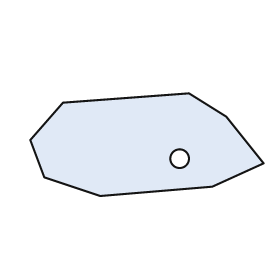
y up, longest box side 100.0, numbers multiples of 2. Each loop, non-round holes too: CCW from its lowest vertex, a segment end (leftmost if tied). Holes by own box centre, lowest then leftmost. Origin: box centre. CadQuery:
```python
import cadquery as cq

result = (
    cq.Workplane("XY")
    .moveTo(-20.0, -22.0)
    .lineTo(28.0, -18.0)
    .lineTo(50.0, -8.0)
    .lineTo(34.0, 12.0)
    .lineTo(18.0, 22.0)
    .lineTo(-36.0, 18.0)
    .lineTo(-50.0, 2.0)
    .lineTo(-44.0, -14.0)
    .close()
    .moveTo(14.0, -6.0)
    .circle(4.0)
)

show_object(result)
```